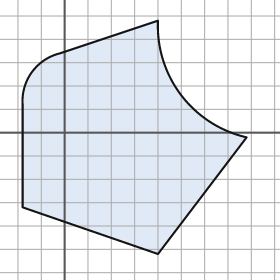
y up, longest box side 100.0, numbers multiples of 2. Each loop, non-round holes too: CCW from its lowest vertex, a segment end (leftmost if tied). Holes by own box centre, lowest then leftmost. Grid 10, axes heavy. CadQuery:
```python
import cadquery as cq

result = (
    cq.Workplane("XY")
    .moveTo(40.0, -52.0)
    .lineTo(78.0, -2.0)
    .threePointArc((50.0, 16.0), (40.0, 48.0))
    .lineTo(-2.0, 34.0)
    .threePointArc((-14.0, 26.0), (-18.0, 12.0))
    .lineTo(-18.0, -32.0)
    .close()
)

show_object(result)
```